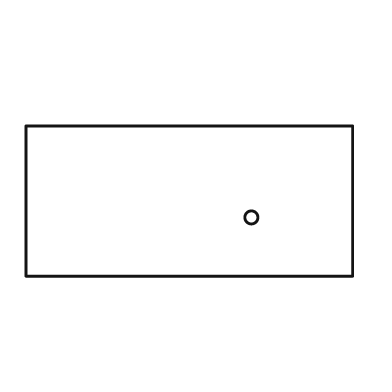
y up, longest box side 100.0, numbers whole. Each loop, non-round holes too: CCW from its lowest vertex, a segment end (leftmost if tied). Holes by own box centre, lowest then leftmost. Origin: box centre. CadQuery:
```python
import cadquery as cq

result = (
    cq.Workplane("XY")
    .moveTo(-50.0, -23.0)
    .lineTo(50.0, -23.0)
    .lineTo(50.0, 23.0)
    .lineTo(-50.0, 23.0)
    .close()
    .moveTo(19.0, -5.0)
    .circle(2.0)
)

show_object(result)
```